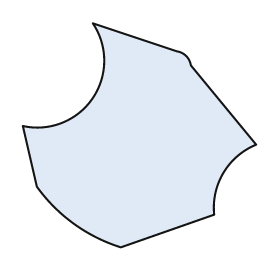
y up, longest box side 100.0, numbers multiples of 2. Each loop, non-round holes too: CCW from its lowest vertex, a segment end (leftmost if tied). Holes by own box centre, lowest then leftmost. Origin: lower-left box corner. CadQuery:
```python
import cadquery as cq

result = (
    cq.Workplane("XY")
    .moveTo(42.0, 0.0)
    .lineTo(82.0, 14.0)
    .threePointArc((86.0, 32.0), (100.0, 44.0))
    .lineTo(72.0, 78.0)
    .threePointArc((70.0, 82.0), (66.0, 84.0))
    .lineTo(30.0, 96.0)
    .threePointArc((30.0, 64.0), (0.0, 52.0))
    .lineTo(6.0, 26.0)
    .threePointArc((22.0, 10.0), (42.0, 0.0))
    .close()
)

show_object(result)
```